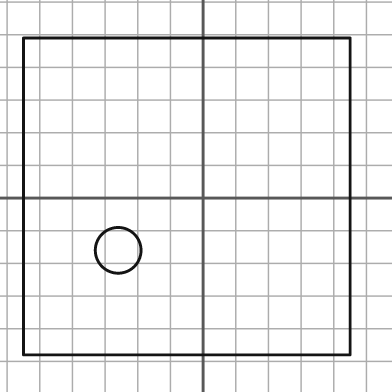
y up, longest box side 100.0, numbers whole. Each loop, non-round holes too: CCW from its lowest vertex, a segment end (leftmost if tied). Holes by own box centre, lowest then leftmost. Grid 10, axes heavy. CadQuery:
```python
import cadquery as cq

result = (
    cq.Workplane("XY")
    .moveTo(-55.0, -48.0)
    .lineTo(45.0, -48.0)
    .lineTo(45.0, 49.0)
    .lineTo(-55.0, 49.0)
    .close()
    .moveTo(-26.0, -16.0)
    .circle(7.0)
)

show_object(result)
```